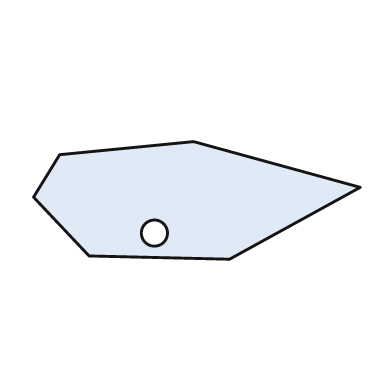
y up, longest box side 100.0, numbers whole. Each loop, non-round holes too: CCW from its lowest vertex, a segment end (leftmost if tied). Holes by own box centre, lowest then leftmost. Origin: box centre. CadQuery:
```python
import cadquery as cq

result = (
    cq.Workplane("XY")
    .moveTo(10.0, -18.0)
    .lineTo(50.0, 4.0)
    .lineTo(-1.0, 18.0)
    .lineTo(-42.0, 14.0)
    .lineTo(-50.0, 1.0)
    .lineTo(-33.0, -17.0)
    .close()
    .moveTo(-13.0, -10.0)
    .circle(4.0)
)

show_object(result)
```